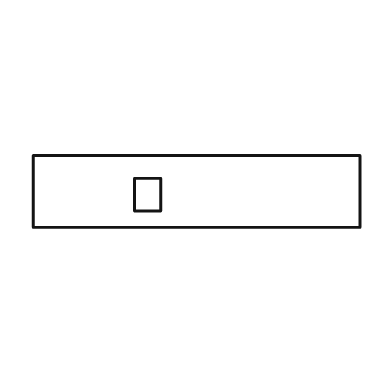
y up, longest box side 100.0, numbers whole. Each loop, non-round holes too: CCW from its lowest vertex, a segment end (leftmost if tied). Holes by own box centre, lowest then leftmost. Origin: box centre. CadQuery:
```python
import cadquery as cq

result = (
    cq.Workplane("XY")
    .moveTo(-50.0, -11.0)
    .lineTo(50.0, -11.0)
    .lineTo(50.0, 11.0)
    .lineTo(-50.0, 11.0)
    .close()
    .moveTo(-19.0, -6.0)
    .lineTo(-11.0, -6.0)
    .lineTo(-11.0, 4.0)
    .lineTo(-19.0, 4.0)
    .close()
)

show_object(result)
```